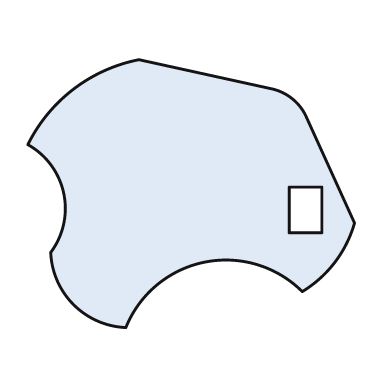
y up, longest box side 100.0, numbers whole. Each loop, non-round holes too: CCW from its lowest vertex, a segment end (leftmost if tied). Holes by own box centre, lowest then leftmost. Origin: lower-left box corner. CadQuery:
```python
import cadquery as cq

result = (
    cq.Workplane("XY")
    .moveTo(30.0, 0.0)
    .threePointArc((54.0, 20.0), (84.0, 11.0))
    .threePointArc((94.0, 20.0), (100.0, 32.0))
    .lineTo(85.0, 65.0)
    .threePointArc((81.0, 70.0), (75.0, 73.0))
    .lineTo(34.0, 82.0)
    .threePointArc((14.0, 73.0), (0.0, 56.0))
    .threePointArc((11.0, 41.0), (7.0, 23.0))
    .threePointArc((14.0, 7.0), (30.0, 0.0))
    .close()
    .moveTo(80.0, 29.0)
    .lineTo(90.0, 29.0)
    .lineTo(90.0, 43.0)
    .lineTo(80.0, 43.0)
    .close()
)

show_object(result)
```